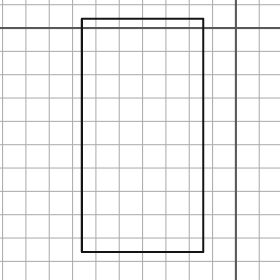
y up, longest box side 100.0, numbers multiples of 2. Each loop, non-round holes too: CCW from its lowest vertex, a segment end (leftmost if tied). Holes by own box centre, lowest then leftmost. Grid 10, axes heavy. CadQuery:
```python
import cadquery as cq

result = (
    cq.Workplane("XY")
    .moveTo(-66.0, -96.0)
    .lineTo(-14.0, -96.0)
    .lineTo(-14.0, 4.0)
    .lineTo(-66.0, 4.0)
    .close()
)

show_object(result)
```